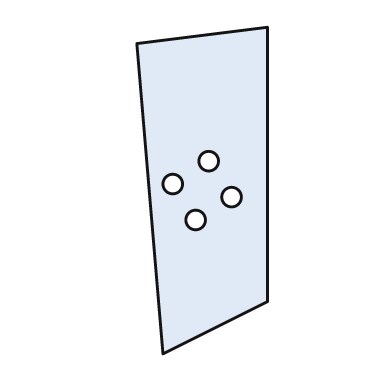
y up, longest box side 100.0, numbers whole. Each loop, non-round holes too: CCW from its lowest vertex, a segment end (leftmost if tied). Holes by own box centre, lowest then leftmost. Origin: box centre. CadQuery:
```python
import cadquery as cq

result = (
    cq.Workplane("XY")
    .moveTo(-12.0, -50.0)
    .lineTo(20.0, -34.0)
    .lineTo(20.0, 50.0)
    .lineTo(-20.0, 45.0)
    .close()
    .moveTo(-2.0, -9.0)
    .circle(3.0)
    .moveTo(9.0, -2.0)
    .circle(3.0)
    .moveTo(-9.0, 2.0)
    .circle(3.0)
    .moveTo(2.0, 9.0)
    .circle(3.0)
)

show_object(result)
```